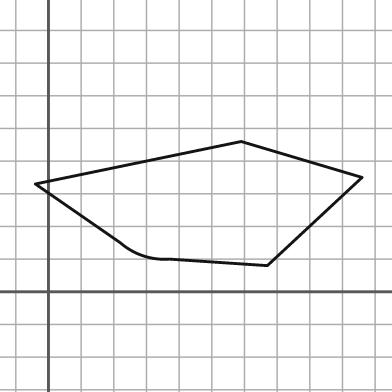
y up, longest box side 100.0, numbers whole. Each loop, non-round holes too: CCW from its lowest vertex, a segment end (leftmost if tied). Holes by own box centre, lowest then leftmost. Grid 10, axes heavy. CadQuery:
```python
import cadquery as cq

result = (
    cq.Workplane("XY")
    .moveTo(67.0, 8.0)
    .lineTo(96.0, 35.0)
    .lineTo(59.0, 46.0)
    .lineTo(-4.0, 33.0)
    .lineTo(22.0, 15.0)
    .threePointArc((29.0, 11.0), (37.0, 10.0))
    .close()
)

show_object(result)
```